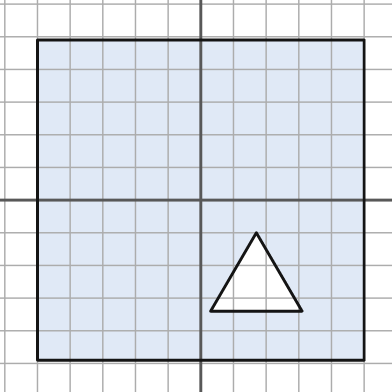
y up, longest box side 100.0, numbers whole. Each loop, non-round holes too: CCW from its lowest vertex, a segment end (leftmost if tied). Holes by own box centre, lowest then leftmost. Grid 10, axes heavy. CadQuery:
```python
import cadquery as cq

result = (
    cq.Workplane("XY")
    .moveTo(-50.0, -49.0)
    .lineTo(50.0, -49.0)
    .lineTo(50.0, 49.0)
    .lineTo(-50.0, 49.0)
    .close()
    .moveTo(3.0, -34.0)
    .lineTo(31.0, -34.0)
    .lineTo(17.0, -10.0)
    .close()
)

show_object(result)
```